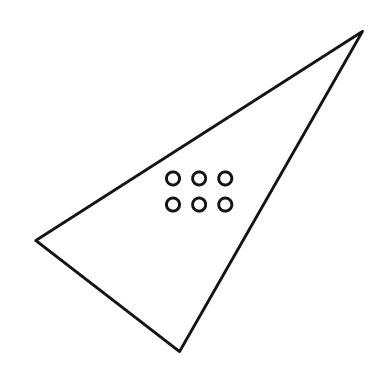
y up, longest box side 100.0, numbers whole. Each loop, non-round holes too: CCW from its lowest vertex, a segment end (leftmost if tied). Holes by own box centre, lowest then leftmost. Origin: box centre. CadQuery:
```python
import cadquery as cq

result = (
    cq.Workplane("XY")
    .moveTo(-6.0, -49.0)
    .lineTo(50.0, 49.0)
    .lineTo(-50.0, -15.0)
    .close()
    .moveTo(-8.0, -4.0)
    .circle(2.0)
    .moveTo(0.0, -4.0)
    .circle(2.0)
    .moveTo(8.0, -4.0)
    .circle(2.0)
    .moveTo(-8.0, 4.0)
    .circle(2.0)
    .moveTo(0.0, 4.0)
    .circle(2.0)
    .moveTo(8.0, 4.0)
    .circle(2.0)
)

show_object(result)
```